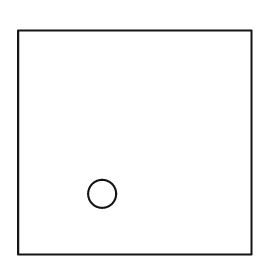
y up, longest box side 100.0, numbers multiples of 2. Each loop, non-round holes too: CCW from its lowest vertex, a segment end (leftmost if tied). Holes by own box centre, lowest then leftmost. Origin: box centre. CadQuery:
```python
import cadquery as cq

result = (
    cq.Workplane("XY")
    .moveTo(-50.0, -48.0)
    .lineTo(50.0, -48.0)
    .lineTo(50.0, 48.0)
    .lineTo(-50.0, 48.0)
    .close()
    .moveTo(-14.0, -22.0)
    .circle(6.0)
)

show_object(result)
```